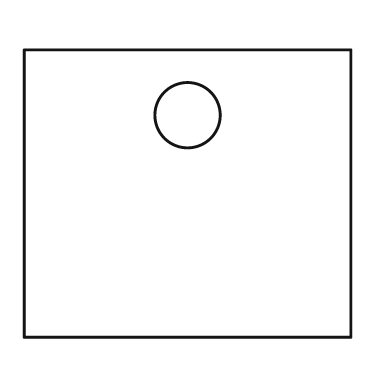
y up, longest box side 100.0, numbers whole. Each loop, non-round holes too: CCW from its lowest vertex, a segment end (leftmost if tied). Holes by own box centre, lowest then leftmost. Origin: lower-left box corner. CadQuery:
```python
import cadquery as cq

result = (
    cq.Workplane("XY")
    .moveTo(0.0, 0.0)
    .lineTo(100.0, 0.0)
    .lineTo(100.0, 88.0)
    .lineTo(0.0, 88.0)
    .close()
    .moveTo(50.0, 68.0)
    .circle(10.0)
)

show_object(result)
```